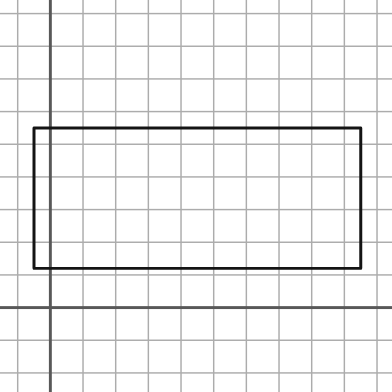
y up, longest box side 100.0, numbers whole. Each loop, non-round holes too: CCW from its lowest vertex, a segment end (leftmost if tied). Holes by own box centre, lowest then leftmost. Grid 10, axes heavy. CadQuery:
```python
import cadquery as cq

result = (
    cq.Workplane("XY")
    .moveTo(-5.0, 12.0)
    .lineTo(95.0, 12.0)
    .lineTo(95.0, 55.0)
    .lineTo(-5.0, 55.0)
    .close()
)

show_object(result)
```